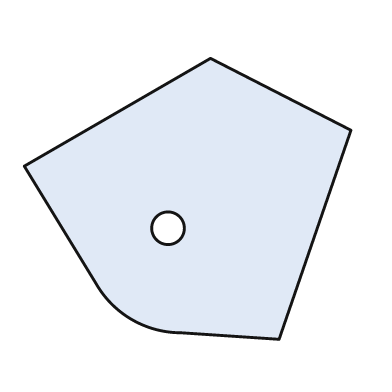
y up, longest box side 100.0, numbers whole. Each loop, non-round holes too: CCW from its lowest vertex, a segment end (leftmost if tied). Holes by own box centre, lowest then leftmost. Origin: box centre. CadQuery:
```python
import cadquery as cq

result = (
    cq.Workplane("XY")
    .moveTo(28.0, -43.0)
    .lineTo(50.0, 21.0)
    .lineTo(7.0, 43.0)
    .lineTo(-50.0, 10.0)
    .lineTo(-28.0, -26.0)
    .threePointArc((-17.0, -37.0), (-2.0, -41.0))
    .close()
    .moveTo(-6.0, -9.0)
    .circle(5.0)
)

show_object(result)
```